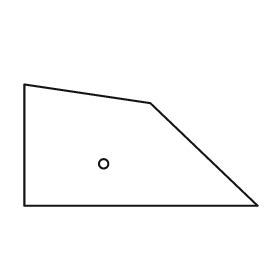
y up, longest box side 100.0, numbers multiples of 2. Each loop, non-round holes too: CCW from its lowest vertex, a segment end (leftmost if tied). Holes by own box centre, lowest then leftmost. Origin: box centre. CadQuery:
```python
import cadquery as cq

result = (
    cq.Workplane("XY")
    .moveTo(-50.0, -26.0)
    .lineTo(50.0, -26.0)
    .lineTo(4.0, 18.0)
    .lineTo(-50.0, 26.0)
    .close()
    .moveTo(-16.0, -8.0)
    .circle(2.0)
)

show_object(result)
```